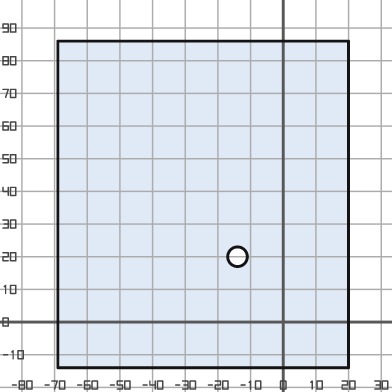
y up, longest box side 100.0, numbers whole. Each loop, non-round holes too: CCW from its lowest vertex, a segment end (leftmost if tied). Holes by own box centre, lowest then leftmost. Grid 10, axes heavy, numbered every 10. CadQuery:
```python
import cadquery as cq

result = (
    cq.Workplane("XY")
    .moveTo(-69.0, -14.0)
    .lineTo(20.0, -14.0)
    .lineTo(20.0, 86.0)
    .lineTo(-69.0, 86.0)
    .close()
    .moveTo(-14.0, 20.0)
    .circle(3.0)
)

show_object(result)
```